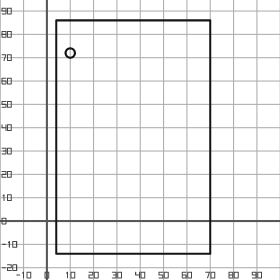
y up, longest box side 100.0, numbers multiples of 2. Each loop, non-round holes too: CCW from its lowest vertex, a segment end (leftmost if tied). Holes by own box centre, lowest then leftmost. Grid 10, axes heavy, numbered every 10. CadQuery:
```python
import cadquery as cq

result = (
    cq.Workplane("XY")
    .moveTo(4.0, -14.0)
    .lineTo(70.0, -14.0)
    .lineTo(70.0, 86.0)
    .lineTo(4.0, 86.0)
    .close()
    .moveTo(10.0, 72.0)
    .circle(2.0)
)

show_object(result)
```